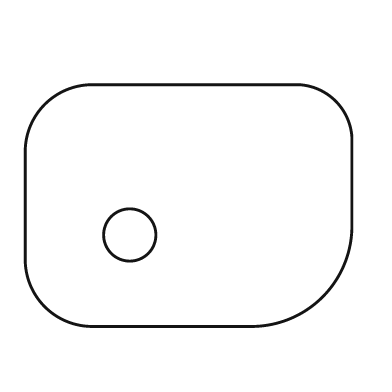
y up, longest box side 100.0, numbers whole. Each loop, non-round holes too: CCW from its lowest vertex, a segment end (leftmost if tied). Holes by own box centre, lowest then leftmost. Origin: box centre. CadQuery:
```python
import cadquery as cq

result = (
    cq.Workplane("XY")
    .moveTo(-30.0, -37.0)
    .lineTo(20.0, -37.0)
    .threePointArc((41.0, -28.0), (50.0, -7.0))
    .lineTo(50.0, 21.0)
    .threePointArc((45.0, 32.0), (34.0, 37.0))
    .lineTo(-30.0, 37.0)
    .threePointArc((-44.0, 31.0), (-50.0, 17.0))
    .lineTo(-50.0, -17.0)
    .threePointArc((-44.0, -31.0), (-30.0, -37.0))
    .close()
    .moveTo(-18.0, -9.0)
    .circle(8.0)
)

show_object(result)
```